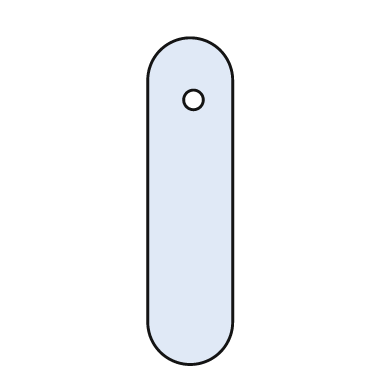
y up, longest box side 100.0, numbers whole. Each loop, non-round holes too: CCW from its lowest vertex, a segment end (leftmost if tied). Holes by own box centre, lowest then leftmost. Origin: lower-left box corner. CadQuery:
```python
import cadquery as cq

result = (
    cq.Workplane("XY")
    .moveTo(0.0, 13.0)
    .threePointArc((13.0, 0.0), (26.0, 13.0))
    .lineTo(26.0, 87.0)
    .threePointArc((13.0, 100.0), (0.0, 87.0))
    .close()
    .moveTo(14.0, 81.0)
    .circle(3.0)
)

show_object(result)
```